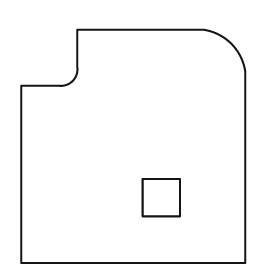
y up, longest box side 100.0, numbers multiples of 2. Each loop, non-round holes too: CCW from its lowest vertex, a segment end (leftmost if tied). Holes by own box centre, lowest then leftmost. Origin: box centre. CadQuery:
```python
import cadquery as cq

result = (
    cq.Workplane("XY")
    .moveTo(-48.0, -50.0)
    .lineTo(48.0, -50.0)
    .lineTo(48.0, 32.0)
    .threePointArc((42.0, 44.0), (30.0, 50.0))
    .lineTo(-24.0, 50.0)
    .lineTo(-24.0, 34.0)
    .threePointArc((-26.0, 28.0), (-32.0, 26.0))
    .lineTo(-48.0, 26.0)
    .close()
    .moveTo(4.0, -30.0)
    .lineTo(20.0, -30.0)
    .lineTo(20.0, -14.0)
    .lineTo(4.0, -14.0)
    .close()
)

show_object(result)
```